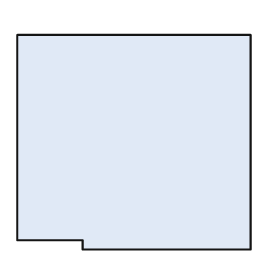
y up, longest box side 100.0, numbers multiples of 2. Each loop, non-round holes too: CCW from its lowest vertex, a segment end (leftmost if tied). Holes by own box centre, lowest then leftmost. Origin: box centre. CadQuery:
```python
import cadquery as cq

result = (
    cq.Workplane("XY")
    .moveTo(-22.0, -46.0)
    .lineTo(50.0, -46.0)
    .lineTo(50.0, 46.0)
    .lineTo(-50.0, 46.0)
    .lineTo(-50.0, -42.0)
    .lineTo(-22.0, -42.0)
    .close()
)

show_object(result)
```